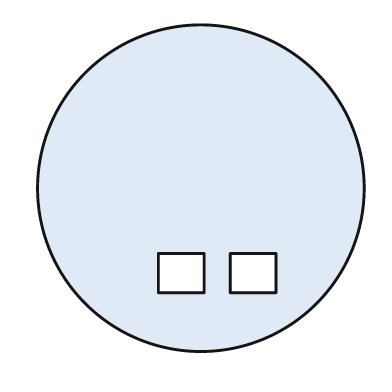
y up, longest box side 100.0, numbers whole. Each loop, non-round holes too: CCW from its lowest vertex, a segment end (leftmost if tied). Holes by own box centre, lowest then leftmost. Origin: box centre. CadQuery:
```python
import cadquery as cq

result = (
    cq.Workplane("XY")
    .moveTo(0.0, 0.0)
    .circle(50.0)
    .moveTo(-13.0, -32.0)
    .lineTo(1.0, -32.0)
    .lineTo(1.0, -20.0)
    .lineTo(-13.0, -20.0)
    .close()
    .moveTo(9.0, -32.0)
    .lineTo(23.0, -32.0)
    .lineTo(23.0, -20.0)
    .lineTo(9.0, -20.0)
    .close()
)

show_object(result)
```